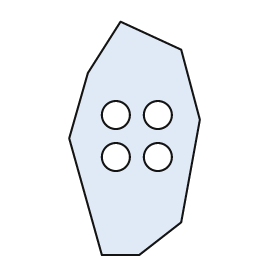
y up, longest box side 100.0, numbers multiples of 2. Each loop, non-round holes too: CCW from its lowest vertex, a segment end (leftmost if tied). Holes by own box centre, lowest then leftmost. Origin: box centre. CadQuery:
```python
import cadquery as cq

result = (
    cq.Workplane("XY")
    .moveTo(-14.0, -50.0)
    .lineTo(2.0, -50.0)
    .lineTo(20.0, -36.0)
    .lineTo(28.0, 8.0)
    .lineTo(20.0, 38.0)
    .lineTo(-6.0, 50.0)
    .lineTo(-20.0, 28.0)
    .lineTo(-28.0, 0.0)
    .close()
    .moveTo(-8.0, -8.0)
    .circle(6.0)
    .moveTo(10.0, -8.0)
    .circle(6.0)
    .moveTo(-8.0, 10.0)
    .circle(6.0)
    .moveTo(10.0, 10.0)
    .circle(6.0)
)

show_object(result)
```